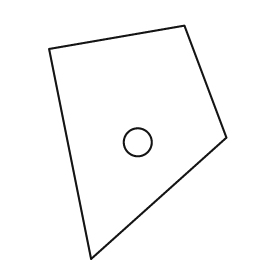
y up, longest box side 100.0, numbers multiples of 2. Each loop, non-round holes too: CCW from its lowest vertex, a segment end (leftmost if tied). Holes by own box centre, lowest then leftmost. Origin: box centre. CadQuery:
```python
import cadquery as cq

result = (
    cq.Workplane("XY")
    .moveTo(-20.0, -50.0)
    .lineTo(38.0, 2.0)
    .lineTo(20.0, 50.0)
    .lineTo(-38.0, 40.0)
    .close()
    .moveTo(0.0, 0.0)
    .circle(6.0)
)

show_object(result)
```